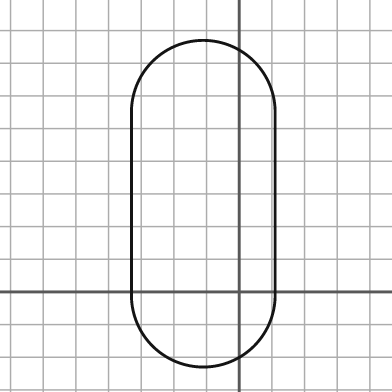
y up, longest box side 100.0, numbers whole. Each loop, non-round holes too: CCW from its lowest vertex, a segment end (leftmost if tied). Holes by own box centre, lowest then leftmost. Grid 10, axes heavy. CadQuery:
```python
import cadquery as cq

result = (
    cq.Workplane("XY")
    .moveTo(-33.0, -1.0)
    .threePointArc((-11.0, -23.0), (11.0, -1.0))
    .lineTo(11.0, 55.0)
    .threePointArc((-11.0, 77.0), (-33.0, 55.0))
    .close()
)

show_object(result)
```